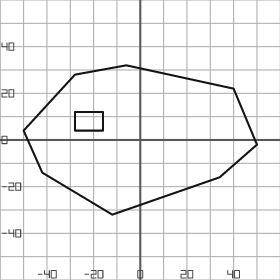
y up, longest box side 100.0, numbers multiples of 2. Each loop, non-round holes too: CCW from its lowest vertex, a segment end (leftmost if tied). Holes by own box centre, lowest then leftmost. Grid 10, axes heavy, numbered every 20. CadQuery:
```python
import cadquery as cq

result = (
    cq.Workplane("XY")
    .moveTo(-12.0, -32.0)
    .lineTo(34.0, -16.0)
    .lineTo(50.0, -2.0)
    .lineTo(40.0, 22.0)
    .lineTo(-6.0, 32.0)
    .lineTo(-28.0, 28.0)
    .lineTo(-50.0, 4.0)
    .lineTo(-42.0, -14.0)
    .close()
    .moveTo(-28.0, 4.0)
    .lineTo(-16.0, 4.0)
    .lineTo(-16.0, 12.0)
    .lineTo(-28.0, 12.0)
    .close()
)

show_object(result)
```